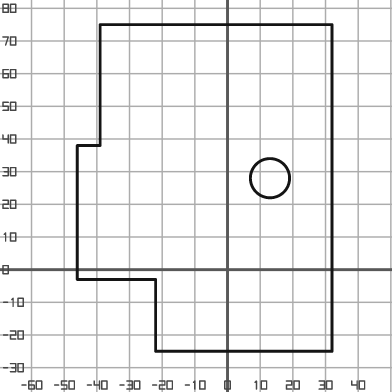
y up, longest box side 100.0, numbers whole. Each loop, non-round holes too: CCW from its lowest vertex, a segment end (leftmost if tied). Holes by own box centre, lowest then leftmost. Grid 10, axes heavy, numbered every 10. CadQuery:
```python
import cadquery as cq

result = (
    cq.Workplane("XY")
    .moveTo(-22.0, -25.0)
    .lineTo(32.0, -25.0)
    .lineTo(32.0, 75.0)
    .lineTo(-39.0, 75.0)
    .lineTo(-39.0, 38.0)
    .lineTo(-46.0, 38.0)
    .lineTo(-46.0, -3.0)
    .lineTo(-22.0, -3.0)
    .close()
    .moveTo(13.0, 28.0)
    .circle(6.0)
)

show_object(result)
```